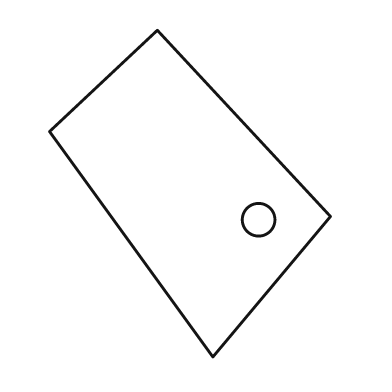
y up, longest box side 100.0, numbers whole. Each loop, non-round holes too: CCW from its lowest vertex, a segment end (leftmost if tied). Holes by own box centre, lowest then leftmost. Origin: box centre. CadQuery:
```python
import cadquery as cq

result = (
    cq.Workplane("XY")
    .moveTo(7.0, -50.0)
    .lineTo(43.0, -7.0)
    .lineTo(-10.0, 50.0)
    .lineTo(-43.0, 19.0)
    .close()
    .moveTo(21.0, -8.0)
    .circle(5.0)
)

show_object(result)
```